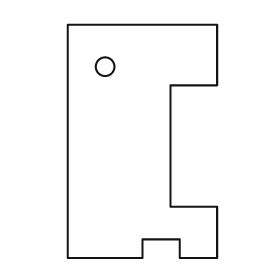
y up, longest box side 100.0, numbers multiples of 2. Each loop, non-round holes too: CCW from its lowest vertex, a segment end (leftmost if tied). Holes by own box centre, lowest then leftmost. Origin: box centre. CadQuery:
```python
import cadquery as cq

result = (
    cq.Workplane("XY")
    .moveTo(-32.0, -50.0)
    .lineTo(0.0, -50.0)
    .lineTo(0.0, -42.0)
    .lineTo(16.0, -42.0)
    .lineTo(16.0, -50.0)
    .lineTo(32.0, -50.0)
    .lineTo(32.0, -28.0)
    .lineTo(12.0, -28.0)
    .lineTo(12.0, 24.0)
    .lineTo(32.0, 24.0)
    .lineTo(32.0, 50.0)
    .lineTo(-32.0, 50.0)
    .close()
    .moveTo(-16.0, 32.0)
    .circle(4.0)
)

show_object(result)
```